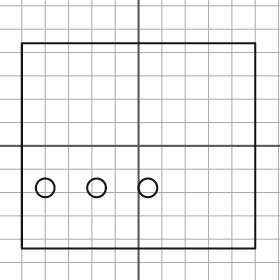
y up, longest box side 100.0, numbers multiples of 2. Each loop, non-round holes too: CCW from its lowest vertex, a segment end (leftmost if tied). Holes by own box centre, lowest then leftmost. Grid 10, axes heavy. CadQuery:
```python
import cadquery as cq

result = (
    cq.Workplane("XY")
    .moveTo(-50.0, -44.0)
    .lineTo(50.0, -44.0)
    .lineTo(50.0, 44.0)
    .lineTo(-50.0, 44.0)
    .close()
    .moveTo(-40.0, -18.0)
    .circle(4.0)
    .moveTo(-18.0, -18.0)
    .circle(4.0)
    .moveTo(4.0, -18.0)
    .circle(4.0)
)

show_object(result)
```